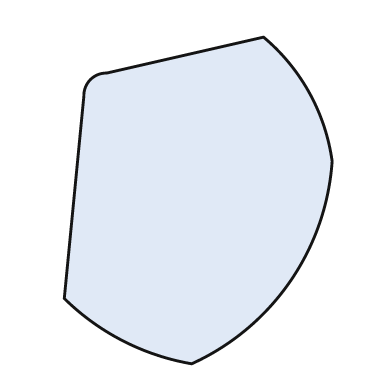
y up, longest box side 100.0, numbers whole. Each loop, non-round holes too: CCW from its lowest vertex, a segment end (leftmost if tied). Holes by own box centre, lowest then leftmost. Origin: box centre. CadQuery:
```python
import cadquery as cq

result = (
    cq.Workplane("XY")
    .moveTo(-2.0, -50.0)
    .threePointArc((28.0, -25.0), (41.0, 12.0))
    .threePointArc((34.0, 33.0), (20.0, 50.0))
    .lineTo(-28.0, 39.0)
    .threePointArc((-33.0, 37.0), (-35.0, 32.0))
    .lineTo(-41.0, -30.0)
    .threePointArc((-23.0, -43.0), (-2.0, -50.0))
    .close()
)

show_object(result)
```